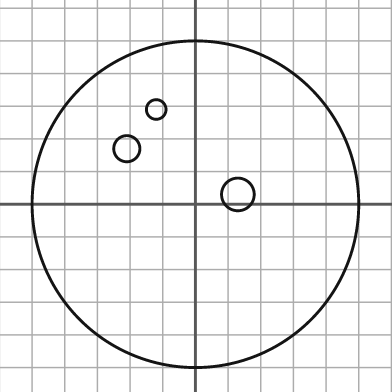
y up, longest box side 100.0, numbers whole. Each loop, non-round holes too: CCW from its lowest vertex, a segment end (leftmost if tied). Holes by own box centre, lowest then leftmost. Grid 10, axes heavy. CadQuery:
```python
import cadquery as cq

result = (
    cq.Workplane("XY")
    .moveTo(0.0, 0.0)
    .circle(50.0)
    .moveTo(13.0, 3.0)
    .circle(5.0)
    .moveTo(-21.0, 17.0)
    .circle(4.0)
    .moveTo(-12.0, 29.0)
    .circle(3.0)
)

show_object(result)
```